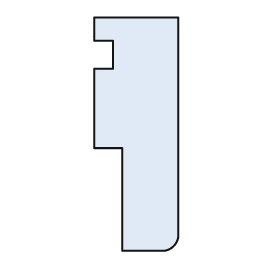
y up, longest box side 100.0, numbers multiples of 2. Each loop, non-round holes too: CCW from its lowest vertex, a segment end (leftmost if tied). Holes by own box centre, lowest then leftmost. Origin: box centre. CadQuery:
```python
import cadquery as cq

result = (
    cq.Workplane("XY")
    .moveTo(-6.0, -50.0)
    .lineTo(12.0, -50.0)
    .threePointArc((16.0, -48.0), (18.0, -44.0))
    .lineTo(18.0, 50.0)
    .lineTo(-18.0, 50.0)
    .lineTo(-18.0, 40.0)
    .lineTo(-10.0, 40.0)
    .lineTo(-10.0, 28.0)
    .lineTo(-18.0, 28.0)
    .lineTo(-18.0, -6.0)
    .lineTo(-6.0, -6.0)
    .close()
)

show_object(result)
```